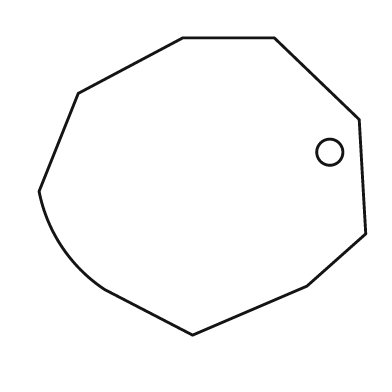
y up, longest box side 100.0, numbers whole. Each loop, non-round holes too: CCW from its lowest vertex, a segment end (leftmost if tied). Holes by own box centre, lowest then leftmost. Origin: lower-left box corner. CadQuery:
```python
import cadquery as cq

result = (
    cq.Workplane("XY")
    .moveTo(47.0, 0.0)
    .lineTo(82.0, 15.0)
    .lineTo(100.0, 31.0)
    .lineTo(98.0, 66.0)
    .lineTo(72.0, 91.0)
    .lineTo(44.0, 91.0)
    .lineTo(12.0, 74.0)
    .lineTo(0.0, 44.0)
    .threePointArc((7.0, 27.0), (20.0, 14.0))
    .close()
    .moveTo(89.0, 56.0)
    .circle(4.0)
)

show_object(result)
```